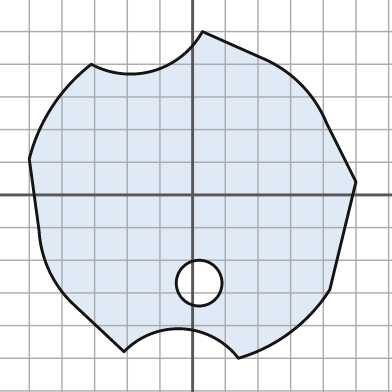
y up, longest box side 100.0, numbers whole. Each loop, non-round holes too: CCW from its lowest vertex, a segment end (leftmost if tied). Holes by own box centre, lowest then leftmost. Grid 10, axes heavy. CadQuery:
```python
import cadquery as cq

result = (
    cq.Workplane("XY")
    .moveTo(14.0, -50.0)
    .threePointArc((30.0, -42.0), (42.0, -29.0))
    .lineTo(50.0, 4.0)
    .lineTo(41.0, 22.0)
    .threePointArc((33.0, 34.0), (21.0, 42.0))
    .lineTo(3.0, 50.0)
    .threePointArc((-12.0, 38.0), (-31.0, 40.0))
    .threePointArc((-43.0, 27.0), (-50.0, 11.0))
    .lineTo(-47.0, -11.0)
    .threePointArc((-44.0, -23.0), (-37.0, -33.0))
    .lineTo(-21.0, -48.0)
    .threePointArc((-3.0, -41.0), (14.0, -50.0))
    .close()
    .moveTo(2.0, -27.0)
    .circle(7.0)
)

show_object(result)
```